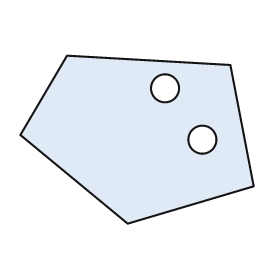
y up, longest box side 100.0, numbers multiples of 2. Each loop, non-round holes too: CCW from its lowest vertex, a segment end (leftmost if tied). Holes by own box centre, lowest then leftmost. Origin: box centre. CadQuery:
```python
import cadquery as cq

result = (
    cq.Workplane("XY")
    .moveTo(-4.0, -36.0)
    .lineTo(50.0, -20.0)
    .lineTo(40.0, 32.0)
    .lineTo(-30.0, 36.0)
    .lineTo(-50.0, 2.0)
    .close()
    .moveTo(28.0, 0.0)
    .circle(6.0)
    .moveTo(12.0, 22.0)
    .circle(6.0)
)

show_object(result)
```